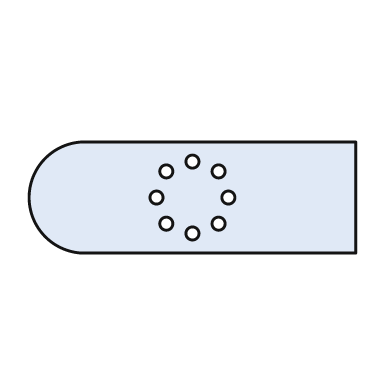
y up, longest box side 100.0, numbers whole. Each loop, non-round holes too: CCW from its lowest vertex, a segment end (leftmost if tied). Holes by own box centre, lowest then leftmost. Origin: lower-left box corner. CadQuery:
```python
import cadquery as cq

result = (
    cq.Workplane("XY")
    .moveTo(16.0, 0.0)
    .lineTo(100.0, 0.0)
    .lineTo(100.0, 34.0)
    .lineTo(16.0, 34.0)
    .threePointArc((0.0, 17.0), (16.0, 0.0))
    .close()
    .moveTo(50.0, 6.0)
    .circle(2.0)
    .moveTo(42.0, 9.0)
    .circle(2.0)
    .moveTo(58.0, 9.0)
    .circle(2.0)
    .moveTo(39.0, 17.0)
    .circle(2.0)
    .moveTo(61.0, 17.0)
    .circle(2.0)
    .moveTo(42.0, 25.0)
    .circle(2.0)
    .moveTo(58.0, 25.0)
    .circle(2.0)
    .moveTo(50.0, 28.0)
    .circle(2.0)
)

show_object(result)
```